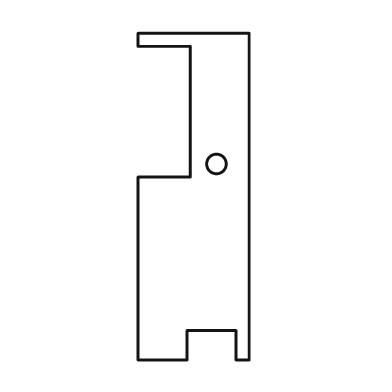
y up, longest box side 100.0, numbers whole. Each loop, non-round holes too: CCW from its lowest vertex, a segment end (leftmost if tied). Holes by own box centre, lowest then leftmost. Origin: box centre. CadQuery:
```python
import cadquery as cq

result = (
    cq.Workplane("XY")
    .moveTo(-17.0, -50.0)
    .lineTo(-2.0, -50.0)
    .lineTo(-2.0, -41.0)
    .lineTo(13.0, -41.0)
    .lineTo(13.0, -50.0)
    .lineTo(17.0, -50.0)
    .lineTo(17.0, 50.0)
    .lineTo(-17.0, 50.0)
    .lineTo(-17.0, 46.0)
    .lineTo(-1.0, 46.0)
    .lineTo(-1.0, 6.0)
    .lineTo(-17.0, 6.0)
    .close()
    .moveTo(7.0, 10.0)
    .circle(3.0)
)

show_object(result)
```